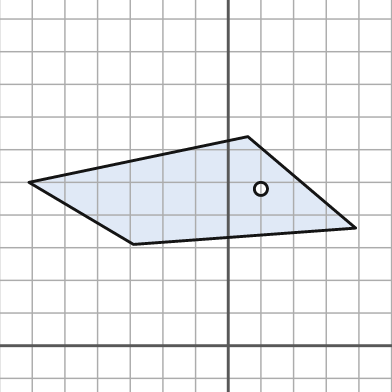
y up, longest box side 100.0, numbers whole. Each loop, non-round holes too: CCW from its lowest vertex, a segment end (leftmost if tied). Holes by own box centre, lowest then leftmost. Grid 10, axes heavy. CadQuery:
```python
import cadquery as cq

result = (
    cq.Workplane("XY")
    .moveTo(-29.0, 31.0)
    .lineTo(39.0, 36.0)
    .lineTo(6.0, 64.0)
    .lineTo(-61.0, 50.0)
    .close()
    .moveTo(10.0, 48.0)
    .circle(2.0)
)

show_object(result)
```